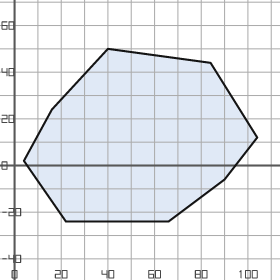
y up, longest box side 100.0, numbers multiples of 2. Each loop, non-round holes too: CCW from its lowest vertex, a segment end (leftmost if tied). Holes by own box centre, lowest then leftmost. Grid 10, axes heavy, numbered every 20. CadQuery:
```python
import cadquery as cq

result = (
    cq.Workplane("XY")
    .moveTo(22.0, -24.0)
    .lineTo(66.0, -24.0)
    .lineTo(90.0, -6.0)
    .lineTo(104.0, 12.0)
    .lineTo(84.0, 44.0)
    .lineTo(40.0, 50.0)
    .lineTo(16.0, 24.0)
    .lineTo(4.0, 2.0)
    .close()
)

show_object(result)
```